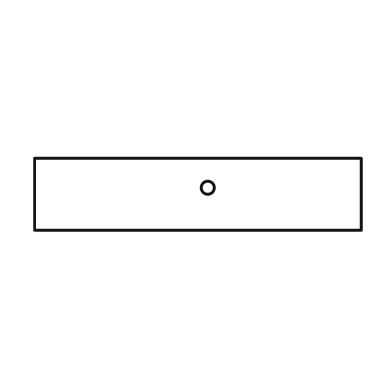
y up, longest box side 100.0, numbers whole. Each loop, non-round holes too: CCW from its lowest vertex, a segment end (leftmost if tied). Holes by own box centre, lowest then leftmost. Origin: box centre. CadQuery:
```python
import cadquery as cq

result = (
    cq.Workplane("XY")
    .moveTo(-50.0, -11.0)
    .lineTo(50.0, -11.0)
    .lineTo(50.0, 11.0)
    .lineTo(-50.0, 11.0)
    .close()
    .moveTo(3.0, 2.0)
    .circle(2.0)
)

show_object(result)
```